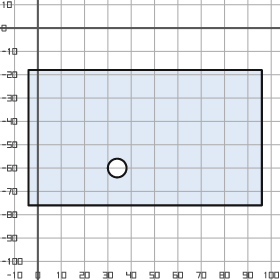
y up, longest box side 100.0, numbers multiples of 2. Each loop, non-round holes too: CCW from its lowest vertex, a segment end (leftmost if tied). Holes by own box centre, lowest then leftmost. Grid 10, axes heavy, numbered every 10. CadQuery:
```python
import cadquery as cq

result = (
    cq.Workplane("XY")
    .moveTo(-4.0, -76.0)
    .lineTo(96.0, -76.0)
    .lineTo(96.0, -18.0)
    .lineTo(-4.0, -18.0)
    .close()
    .moveTo(34.0, -60.0)
    .circle(4.0)
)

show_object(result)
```